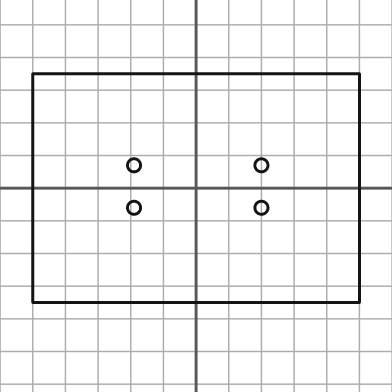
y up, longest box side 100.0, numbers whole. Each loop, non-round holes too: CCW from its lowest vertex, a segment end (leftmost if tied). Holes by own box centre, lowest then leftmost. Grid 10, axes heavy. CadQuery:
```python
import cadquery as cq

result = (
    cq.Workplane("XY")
    .moveTo(-50.0, -35.0)
    .lineTo(50.0, -35.0)
    .lineTo(50.0, 35.0)
    .lineTo(-50.0, 35.0)
    .close()
    .moveTo(-19.0, -6.0)
    .circle(2.0)
    .moveTo(20.0, -6.0)
    .circle(2.0)
    .moveTo(-19.0, 7.0)
    .circle(2.0)
    .moveTo(20.0, 7.0)
    .circle(2.0)
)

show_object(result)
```